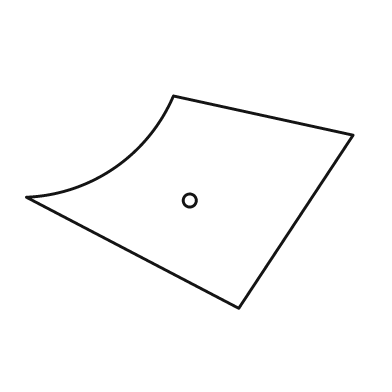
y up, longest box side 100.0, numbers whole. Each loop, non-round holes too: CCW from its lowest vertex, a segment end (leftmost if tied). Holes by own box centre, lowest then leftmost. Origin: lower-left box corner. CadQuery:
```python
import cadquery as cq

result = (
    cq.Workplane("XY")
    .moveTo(65.0, 0.0)
    .lineTo(100.0, 53.0)
    .lineTo(45.0, 65.0)
    .threePointArc((27.0, 43.0), (0.0, 34.0))
    .close()
    .moveTo(50.0, 33.0)
    .circle(2.0)
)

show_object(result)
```